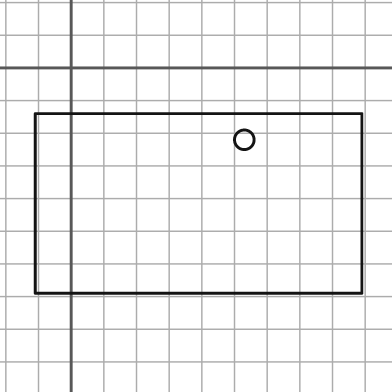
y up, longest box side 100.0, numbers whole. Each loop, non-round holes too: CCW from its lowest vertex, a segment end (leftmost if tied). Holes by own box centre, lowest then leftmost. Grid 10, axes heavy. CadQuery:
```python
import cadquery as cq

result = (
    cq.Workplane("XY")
    .moveTo(-11.0, -69.0)
    .lineTo(89.0, -69.0)
    .lineTo(89.0, -14.0)
    .lineTo(-11.0, -14.0)
    .close()
    .moveTo(53.0, -22.0)
    .circle(3.0)
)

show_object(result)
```